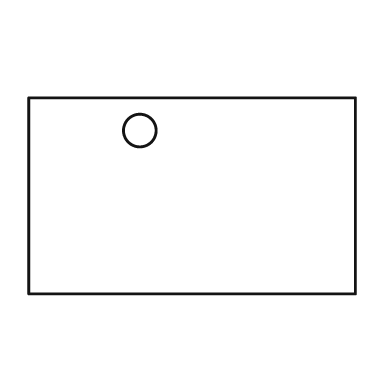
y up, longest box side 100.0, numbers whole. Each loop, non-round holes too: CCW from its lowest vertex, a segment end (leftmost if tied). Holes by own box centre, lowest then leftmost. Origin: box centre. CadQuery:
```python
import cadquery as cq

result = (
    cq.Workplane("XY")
    .moveTo(-50.0, -30.0)
    .lineTo(50.0, -30.0)
    .lineTo(50.0, 30.0)
    .lineTo(-50.0, 30.0)
    .close()
    .moveTo(-16.0, 20.0)
    .circle(5.0)
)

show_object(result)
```